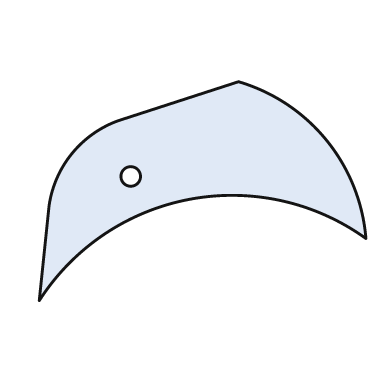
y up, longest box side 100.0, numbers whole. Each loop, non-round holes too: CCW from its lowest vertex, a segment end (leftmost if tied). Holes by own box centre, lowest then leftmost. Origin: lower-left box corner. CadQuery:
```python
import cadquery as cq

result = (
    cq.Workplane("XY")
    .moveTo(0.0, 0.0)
    .threePointArc((46.0, 31.0), (100.0, 19.0))
    .threePointArc((88.0, 49.0), (61.0, 67.0))
    .lineTo(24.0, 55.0)
    .threePointArc((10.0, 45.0), (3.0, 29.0))
    .close()
    .moveTo(28.0, 38.0)
    .circle(3.0)
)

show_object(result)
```